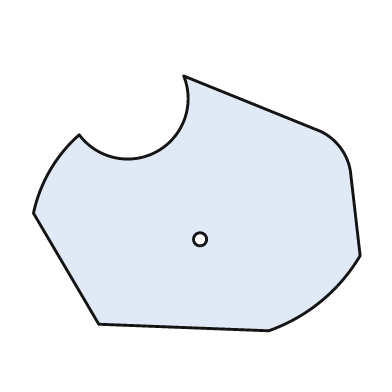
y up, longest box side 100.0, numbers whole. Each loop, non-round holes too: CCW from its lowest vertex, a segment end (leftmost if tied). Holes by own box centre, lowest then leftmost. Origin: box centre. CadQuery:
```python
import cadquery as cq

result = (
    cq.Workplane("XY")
    .moveTo(22.0, -39.0)
    .threePointArc((38.0, -30.0), (50.0, -16.0))
    .lineTo(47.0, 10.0)
    .threePointArc((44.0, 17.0), (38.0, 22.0))
    .lineTo(-4.0, 39.0)
    .threePointArc((-12.0, 16.0), (-36.0, 21.0))
    .threePointArc((-45.0, 10.0), (-50.0, -3.0))
    .lineTo(-30.0, -37.0)
    .close()
    .moveTo(1.0, -11.0)
    .circle(2.0)
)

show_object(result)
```